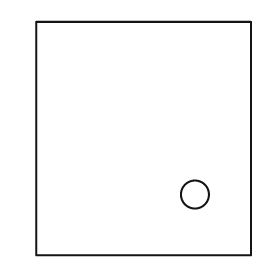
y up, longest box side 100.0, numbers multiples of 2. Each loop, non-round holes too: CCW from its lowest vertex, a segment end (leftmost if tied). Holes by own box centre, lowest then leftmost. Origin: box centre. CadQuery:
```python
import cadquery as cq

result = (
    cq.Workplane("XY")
    .moveTo(-46.0, -50.0)
    .lineTo(46.0, -50.0)
    .lineTo(46.0, 50.0)
    .lineTo(-46.0, 50.0)
    .close()
    .moveTo(22.0, -24.0)
    .circle(6.0)
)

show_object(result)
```